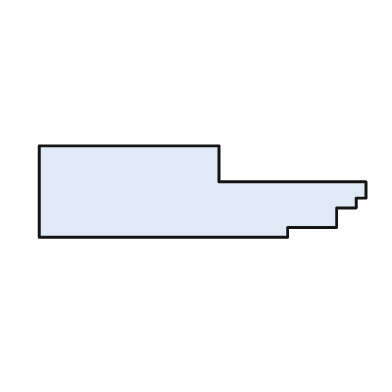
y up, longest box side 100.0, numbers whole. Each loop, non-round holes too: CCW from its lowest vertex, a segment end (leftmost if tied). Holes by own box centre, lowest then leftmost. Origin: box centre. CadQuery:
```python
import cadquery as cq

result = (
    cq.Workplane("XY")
    .moveTo(-50.0, -14.0)
    .lineTo(26.0, -14.0)
    .lineTo(26.0, -11.0)
    .lineTo(41.0, -11.0)
    .lineTo(41.0, -5.0)
    .lineTo(47.0, -5.0)
    .lineTo(47.0, -2.0)
    .lineTo(50.0, -2.0)
    .lineTo(50.0, 3.0)
    .lineTo(5.0, 3.0)
    .lineTo(5.0, 14.0)
    .lineTo(-50.0, 14.0)
    .close()
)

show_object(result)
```